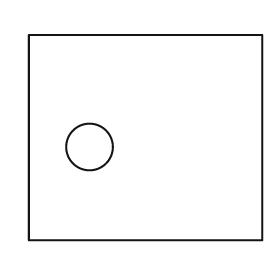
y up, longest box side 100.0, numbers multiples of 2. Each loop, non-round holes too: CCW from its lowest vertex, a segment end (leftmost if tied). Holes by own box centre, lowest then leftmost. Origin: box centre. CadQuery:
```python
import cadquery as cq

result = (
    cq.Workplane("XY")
    .moveTo(-50.0, -44.0)
    .lineTo(50.0, -44.0)
    .lineTo(50.0, 44.0)
    .lineTo(-50.0, 44.0)
    .close()
    .moveTo(-24.0, -4.0)
    .circle(10.0)
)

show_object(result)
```